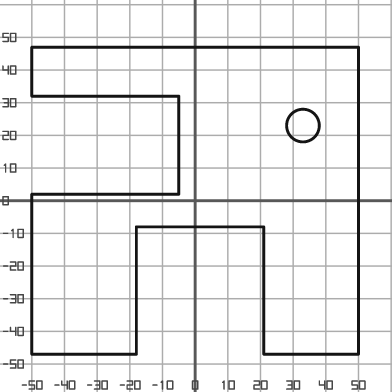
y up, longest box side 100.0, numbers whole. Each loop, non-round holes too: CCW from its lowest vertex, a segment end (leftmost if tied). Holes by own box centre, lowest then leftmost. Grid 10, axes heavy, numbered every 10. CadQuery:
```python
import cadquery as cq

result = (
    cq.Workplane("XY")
    .moveTo(-50.0, -47.0)
    .lineTo(-18.0, -47.0)
    .lineTo(-18.0, -8.0)
    .lineTo(21.0, -8.0)
    .lineTo(21.0, -47.0)
    .lineTo(50.0, -47.0)
    .lineTo(50.0, 47.0)
    .lineTo(-50.0, 47.0)
    .lineTo(-50.0, 32.0)
    .lineTo(-5.0, 32.0)
    .lineTo(-5.0, 2.0)
    .lineTo(-50.0, 2.0)
    .close()
    .moveTo(33.0, 23.0)
    .circle(5.0)
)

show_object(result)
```